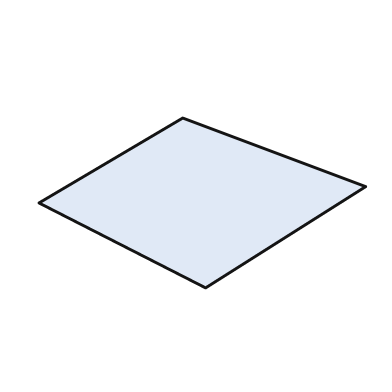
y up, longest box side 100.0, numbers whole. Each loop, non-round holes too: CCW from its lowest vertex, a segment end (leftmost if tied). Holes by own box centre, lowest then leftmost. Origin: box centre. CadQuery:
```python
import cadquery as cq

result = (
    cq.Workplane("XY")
    .moveTo(1.0, -26.0)
    .lineTo(50.0, 5.0)
    .lineTo(-6.0, 26.0)
    .lineTo(-50.0, 0.0)
    .close()
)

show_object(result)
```